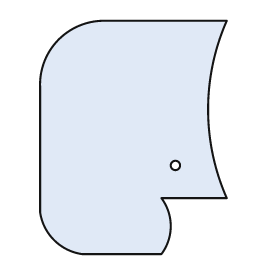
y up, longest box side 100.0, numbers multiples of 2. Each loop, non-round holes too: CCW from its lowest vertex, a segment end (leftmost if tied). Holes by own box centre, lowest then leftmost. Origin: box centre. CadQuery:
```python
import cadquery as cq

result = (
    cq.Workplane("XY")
    .moveTo(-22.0, -50.0)
    .lineTo(12.0, -50.0)
    .threePointArc((16.0, -38.0), (12.0, -26.0))
    .lineTo(40.0, -26.0)
    .threePointArc((32.0, 12.0), (40.0, 50.0))
    .lineTo(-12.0, 50.0)
    .threePointArc((-32.0, 42.0), (-40.0, 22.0))
    .lineTo(-40.0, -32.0)
    .threePointArc((-34.0, -44.0), (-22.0, -50.0))
    .close()
    .moveTo(18.0, -12.0)
    .circle(2.0)
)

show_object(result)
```